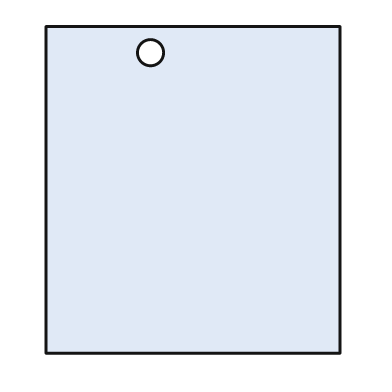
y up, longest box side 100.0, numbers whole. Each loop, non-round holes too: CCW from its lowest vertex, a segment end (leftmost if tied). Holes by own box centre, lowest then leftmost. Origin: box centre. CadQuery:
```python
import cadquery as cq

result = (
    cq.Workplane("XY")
    .moveTo(-45.0, -50.0)
    .lineTo(45.0, -50.0)
    .lineTo(45.0, 50.0)
    .lineTo(-45.0, 50.0)
    .close()
    .moveTo(-13.0, 42.0)
    .circle(4.0)
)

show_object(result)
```